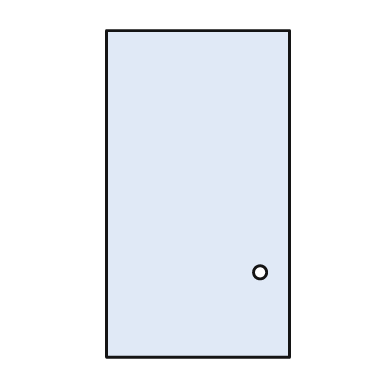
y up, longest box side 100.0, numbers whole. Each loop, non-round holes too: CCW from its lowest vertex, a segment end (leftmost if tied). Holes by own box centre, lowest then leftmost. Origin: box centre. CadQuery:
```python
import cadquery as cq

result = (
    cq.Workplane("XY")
    .moveTo(-28.0, -50.0)
    .lineTo(28.0, -50.0)
    .lineTo(28.0, 50.0)
    .lineTo(-28.0, 50.0)
    .close()
    .moveTo(19.0, -24.0)
    .circle(2.0)
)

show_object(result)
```